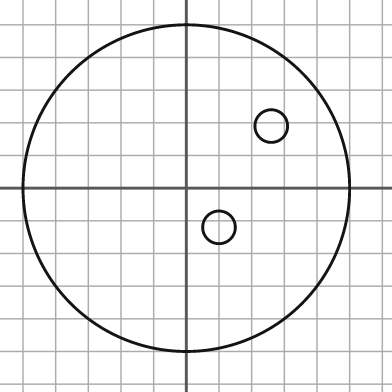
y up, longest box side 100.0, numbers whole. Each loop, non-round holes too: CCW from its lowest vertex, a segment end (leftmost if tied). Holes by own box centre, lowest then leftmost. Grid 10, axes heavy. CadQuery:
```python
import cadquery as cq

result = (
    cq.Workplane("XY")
    .moveTo(0.0, 0.0)
    .circle(50.0)
    .moveTo(10.0, -12.0)
    .circle(5.0)
    .moveTo(26.0, 19.0)
    .circle(5.0)
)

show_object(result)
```